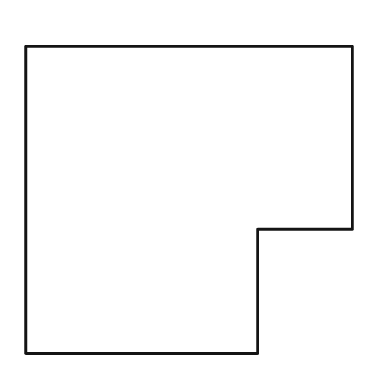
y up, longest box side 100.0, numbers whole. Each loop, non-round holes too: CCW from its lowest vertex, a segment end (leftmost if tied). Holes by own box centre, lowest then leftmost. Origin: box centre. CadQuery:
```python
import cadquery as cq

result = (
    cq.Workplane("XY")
    .moveTo(-50.0, -47.0)
    .lineTo(21.0, -47.0)
    .lineTo(21.0, -9.0)
    .lineTo(50.0, -9.0)
    .lineTo(50.0, 47.0)
    .lineTo(-50.0, 47.0)
    .close()
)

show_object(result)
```